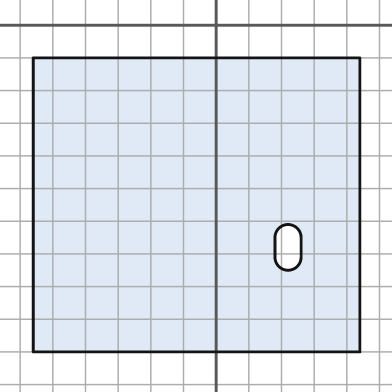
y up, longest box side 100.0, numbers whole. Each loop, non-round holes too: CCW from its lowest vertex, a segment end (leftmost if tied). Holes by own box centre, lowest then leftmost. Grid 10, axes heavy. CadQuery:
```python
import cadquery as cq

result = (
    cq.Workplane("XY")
    .moveTo(-56.0, -100.0)
    .lineTo(44.0, -100.0)
    .lineTo(44.0, -10.0)
    .lineTo(-56.0, -10.0)
    .close()
    .moveTo(18.0, -71.0)
    .threePointArc((22.0, -75.0), (26.0, -71.0))
    .lineTo(26.0, -65.0)
    .threePointArc((22.0, -61.0), (18.0, -65.0))
    .close()
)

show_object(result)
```